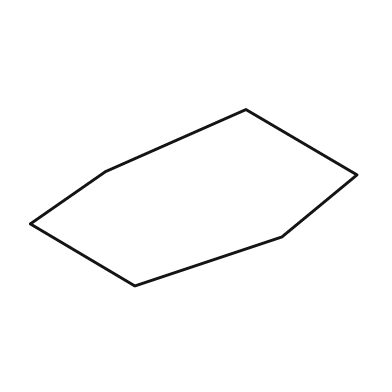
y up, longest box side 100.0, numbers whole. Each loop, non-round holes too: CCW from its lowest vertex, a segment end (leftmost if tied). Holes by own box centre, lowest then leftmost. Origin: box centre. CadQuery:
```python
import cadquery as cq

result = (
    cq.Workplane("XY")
    .moveTo(-18.0, -27.0)
    .lineTo(27.0, -12.0)
    .lineTo(50.0, 7.0)
    .lineTo(16.0, 27.0)
    .lineTo(-27.0, 8.0)
    .lineTo(-50.0, -8.0)
    .close()
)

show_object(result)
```